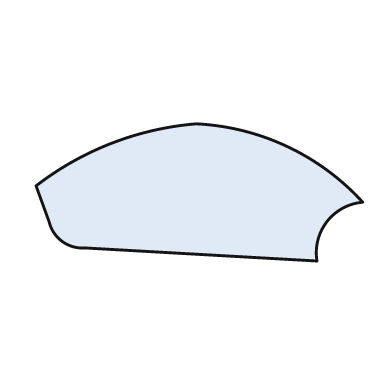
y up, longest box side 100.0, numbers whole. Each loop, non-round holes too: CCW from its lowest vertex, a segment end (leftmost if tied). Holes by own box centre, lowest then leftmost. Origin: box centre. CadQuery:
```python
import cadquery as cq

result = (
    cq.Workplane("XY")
    .moveTo(36.0, -21.0)
    .threePointArc((39.0, -9.0), (50.0, -3.0))
    .threePointArc((27.0, 14.0), (-1.0, 21.0))
    .threePointArc((-27.0, 15.0), (-50.0, 2.0))
    .lineTo(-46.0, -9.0)
    .threePointArc((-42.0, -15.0), (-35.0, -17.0))
    .close()
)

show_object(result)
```